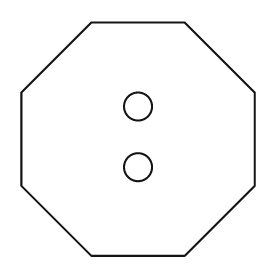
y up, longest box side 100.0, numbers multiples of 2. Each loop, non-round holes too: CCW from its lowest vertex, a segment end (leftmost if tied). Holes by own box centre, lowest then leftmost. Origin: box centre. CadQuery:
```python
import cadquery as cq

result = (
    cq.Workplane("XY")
    .moveTo(-20.0, -50.0)
    .lineTo(20.0, -50.0)
    .lineTo(50.0, -20.0)
    .lineTo(50.0, 20.0)
    .lineTo(20.0, 50.0)
    .lineTo(-20.0, 50.0)
    .lineTo(-50.0, 20.0)
    .lineTo(-50.0, -20.0)
    .close()
    .moveTo(0.0, -12.0)
    .circle(6.0)
    .moveTo(0.0, 14.0)
    .circle(6.0)
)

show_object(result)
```